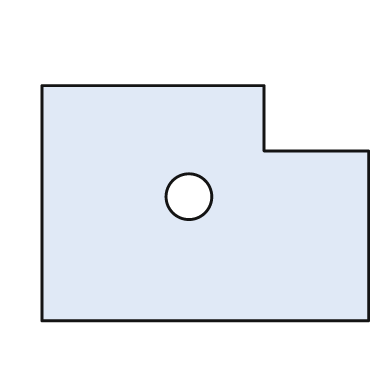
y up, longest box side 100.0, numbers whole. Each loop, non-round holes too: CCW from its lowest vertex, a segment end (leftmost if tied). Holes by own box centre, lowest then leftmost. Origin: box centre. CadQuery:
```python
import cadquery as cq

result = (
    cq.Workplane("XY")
    .moveTo(-50.0, -36.0)
    .lineTo(50.0, -36.0)
    .lineTo(50.0, 16.0)
    .lineTo(18.0, 16.0)
    .lineTo(18.0, 36.0)
    .lineTo(-50.0, 36.0)
    .close()
    .moveTo(-5.0, 2.0)
    .circle(7.0)
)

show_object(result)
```